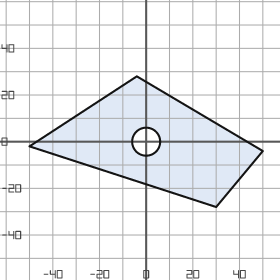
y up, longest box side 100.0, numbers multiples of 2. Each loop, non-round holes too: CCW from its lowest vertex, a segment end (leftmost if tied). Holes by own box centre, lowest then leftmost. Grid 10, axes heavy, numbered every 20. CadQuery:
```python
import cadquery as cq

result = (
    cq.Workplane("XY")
    .moveTo(30.0, -28.0)
    .lineTo(50.0, -4.0)
    .lineTo(-4.0, 28.0)
    .lineTo(-50.0, -2.0)
    .close()
    .moveTo(0.0, 0.0)
    .circle(6.0)
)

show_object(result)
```